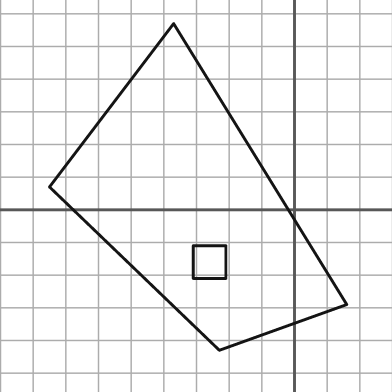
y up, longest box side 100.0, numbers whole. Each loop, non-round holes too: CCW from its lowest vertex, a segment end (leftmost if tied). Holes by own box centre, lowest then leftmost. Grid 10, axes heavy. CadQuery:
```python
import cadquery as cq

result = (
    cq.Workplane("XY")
    .moveTo(-23.0, -43.0)
    .lineTo(16.0, -29.0)
    .lineTo(-37.0, 57.0)
    .lineTo(-75.0, 7.0)
    .close()
    .moveTo(-31.0, -21.0)
    .lineTo(-21.0, -21.0)
    .lineTo(-21.0, -11.0)
    .lineTo(-31.0, -11.0)
    .close()
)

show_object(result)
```